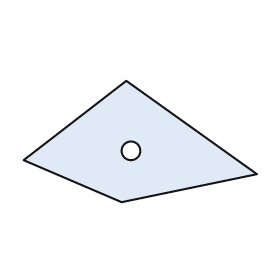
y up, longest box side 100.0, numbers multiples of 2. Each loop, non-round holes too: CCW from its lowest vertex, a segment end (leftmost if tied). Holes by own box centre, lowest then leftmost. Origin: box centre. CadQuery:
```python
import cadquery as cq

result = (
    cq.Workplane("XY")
    .moveTo(-8.0, -26.0)
    .lineTo(50.0, -14.0)
    .lineTo(-6.0, 26.0)
    .lineTo(-50.0, -8.0)
    .close()
    .moveTo(-4.0, -4.0)
    .circle(4.0)
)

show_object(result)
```